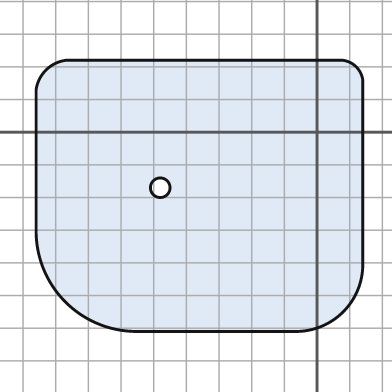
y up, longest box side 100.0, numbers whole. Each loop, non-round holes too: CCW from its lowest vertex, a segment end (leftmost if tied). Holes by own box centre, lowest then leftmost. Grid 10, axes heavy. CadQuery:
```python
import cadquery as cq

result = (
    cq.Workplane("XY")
    .moveTo(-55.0, -61.0)
    .lineTo(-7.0, -61.0)
    .threePointArc((8.0, -55.0), (14.0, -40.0))
    .lineTo(14.0, 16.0)
    .threePointArc((12.0, 20.0), (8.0, 22.0))
    .lineTo(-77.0, 22.0)
    .threePointArc((-83.0, 19.0), (-86.0, 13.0))
    .lineTo(-86.0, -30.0)
    .threePointArc((-77.0, -52.0), (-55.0, -61.0))
    .close()
    .moveTo(-48.0, -17.0)
    .circle(3.0)
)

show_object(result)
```